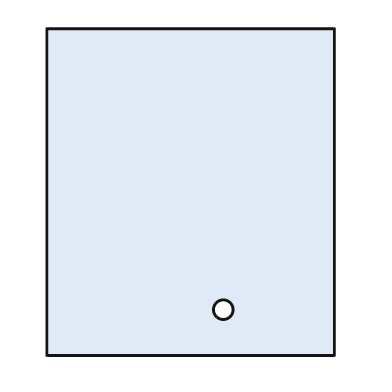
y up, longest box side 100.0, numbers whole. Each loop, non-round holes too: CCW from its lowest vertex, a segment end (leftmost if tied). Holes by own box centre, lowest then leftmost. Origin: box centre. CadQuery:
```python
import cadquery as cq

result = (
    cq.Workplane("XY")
    .moveTo(-44.0, -50.0)
    .lineTo(44.0, -50.0)
    .lineTo(44.0, 50.0)
    .lineTo(-44.0, 50.0)
    .close()
    .moveTo(10.0, -36.0)
    .circle(3.0)
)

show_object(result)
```